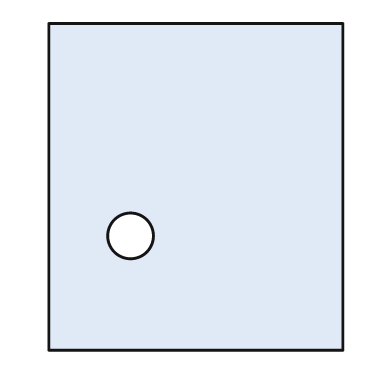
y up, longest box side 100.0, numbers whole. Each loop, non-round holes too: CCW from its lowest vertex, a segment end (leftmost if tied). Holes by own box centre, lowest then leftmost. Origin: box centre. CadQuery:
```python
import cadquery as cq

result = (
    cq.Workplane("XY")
    .moveTo(-45.0, -50.0)
    .lineTo(45.0, -50.0)
    .lineTo(45.0, 50.0)
    .lineTo(-45.0, 50.0)
    .close()
    .moveTo(-20.0, -15.0)
    .circle(7.0)
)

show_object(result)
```